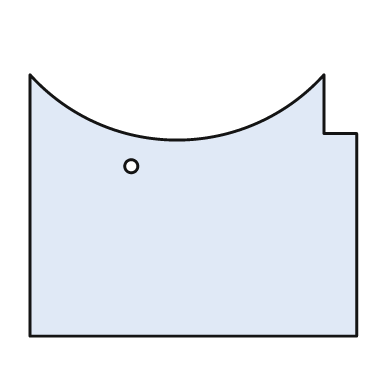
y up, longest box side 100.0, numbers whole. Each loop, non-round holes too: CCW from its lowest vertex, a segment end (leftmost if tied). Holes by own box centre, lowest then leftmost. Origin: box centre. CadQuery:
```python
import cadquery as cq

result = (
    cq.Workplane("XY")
    .moveTo(-50.0, -40.0)
    .lineTo(50.0, -40.0)
    .lineTo(50.0, 22.0)
    .lineTo(40.0, 22.0)
    .lineTo(40.0, 40.0)
    .threePointArc((-5.0, 20.0), (-50.0, 40.0))
    .close()
    .moveTo(-19.0, 12.0)
    .circle(2.0)
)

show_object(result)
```